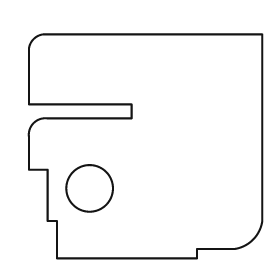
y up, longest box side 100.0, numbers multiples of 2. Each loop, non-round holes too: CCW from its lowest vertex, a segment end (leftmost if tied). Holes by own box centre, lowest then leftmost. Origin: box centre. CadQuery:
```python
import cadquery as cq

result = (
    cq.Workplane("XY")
    .moveTo(-38.0, -48.0)
    .lineTo(22.0, -48.0)
    .lineTo(22.0, -44.0)
    .lineTo(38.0, -44.0)
    .threePointArc((46.0, -40.0), (50.0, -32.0))
    .lineTo(50.0, 48.0)
    .lineTo(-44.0, 48.0)
    .threePointArc((-48.0, 46.0), (-50.0, 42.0))
    .lineTo(-50.0, 18.0)
    .lineTo(-6.0, 18.0)
    .lineTo(-6.0, 12.0)
    .lineTo(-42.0, 12.0)
    .threePointArc((-48.0, 10.0), (-50.0, 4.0))
    .lineTo(-50.0, -10.0)
    .lineTo(-42.0, -10.0)
    .lineTo(-42.0, -32.0)
    .lineTo(-38.0, -32.0)
    .close()
    .moveTo(-24.0, -18.0)
    .circle(10.0)
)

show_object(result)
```